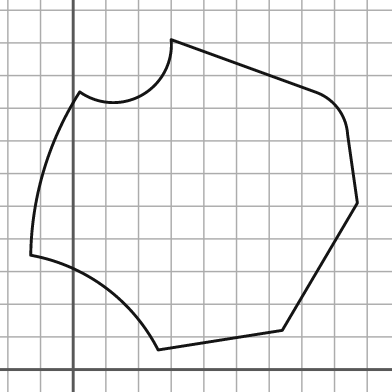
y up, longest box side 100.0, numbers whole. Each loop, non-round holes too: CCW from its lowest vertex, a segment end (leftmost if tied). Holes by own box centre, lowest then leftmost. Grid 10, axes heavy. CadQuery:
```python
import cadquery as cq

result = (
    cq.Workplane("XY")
    .moveTo(26.0, 6.0)
    .lineTo(64.0, 12.0)
    .lineTo(87.0, 51.0)
    .lineTo(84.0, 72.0)
    .threePointArc((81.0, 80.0), (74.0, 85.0))
    .lineTo(30.0, 101.0)
    .threePointArc((21.0, 84.0), (2.0, 85.0))
    .threePointArc((-9.0, 61.0), (-13.0, 35.0))
    .threePointArc((10.0, 25.0), (26.0, 6.0))
    .close()
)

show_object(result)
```